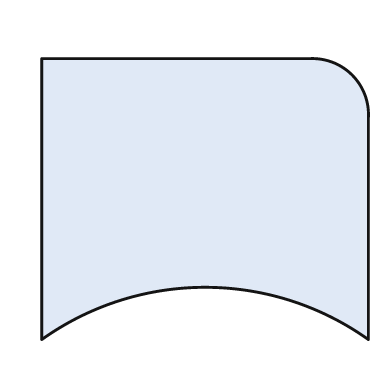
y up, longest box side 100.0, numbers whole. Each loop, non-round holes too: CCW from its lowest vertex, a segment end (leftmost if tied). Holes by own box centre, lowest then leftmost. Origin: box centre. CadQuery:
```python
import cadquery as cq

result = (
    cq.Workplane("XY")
    .moveTo(-50.0, -43.0)
    .threePointArc((0.0, -27.0), (50.0, -43.0))
    .lineTo(50.0, 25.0)
    .threePointArc((45.0, 38.0), (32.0, 43.0))
    .lineTo(-50.0, 43.0)
    .close()
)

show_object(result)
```